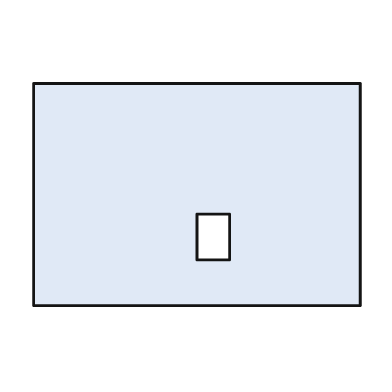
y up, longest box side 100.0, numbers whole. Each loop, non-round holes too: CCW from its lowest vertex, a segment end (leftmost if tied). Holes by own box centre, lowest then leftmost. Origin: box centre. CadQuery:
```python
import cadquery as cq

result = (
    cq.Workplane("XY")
    .moveTo(-50.0, -34.0)
    .lineTo(50.0, -34.0)
    .lineTo(50.0, 34.0)
    .lineTo(-50.0, 34.0)
    .close()
    .moveTo(0.0, -20.0)
    .lineTo(10.0, -20.0)
    .lineTo(10.0, -6.0)
    .lineTo(0.0, -6.0)
    .close()
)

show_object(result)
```